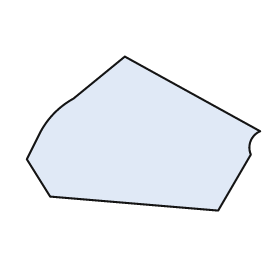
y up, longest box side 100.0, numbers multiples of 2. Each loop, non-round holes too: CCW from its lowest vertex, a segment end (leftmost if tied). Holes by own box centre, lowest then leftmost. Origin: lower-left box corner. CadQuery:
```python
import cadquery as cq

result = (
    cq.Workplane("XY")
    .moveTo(82.0, 0.0)
    .lineTo(96.0, 24.0)
    .threePointArc((96.0, 30.0), (100.0, 34.0))
    .lineTo(42.0, 66.0)
    .lineTo(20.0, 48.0)
    .threePointArc((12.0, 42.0), (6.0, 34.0))
    .lineTo(0.0, 22.0)
    .lineTo(10.0, 6.0)
    .close()
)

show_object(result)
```